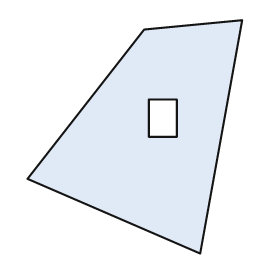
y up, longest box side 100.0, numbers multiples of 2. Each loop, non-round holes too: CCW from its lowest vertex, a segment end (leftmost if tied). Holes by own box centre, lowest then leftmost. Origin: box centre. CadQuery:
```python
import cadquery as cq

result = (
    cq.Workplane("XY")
    .moveTo(28.0, -50.0)
    .lineTo(46.0, 50.0)
    .lineTo(4.0, 46.0)
    .lineTo(-46.0, -18.0)
    .close()
    .moveTo(6.0, 0.0)
    .lineTo(18.0, 0.0)
    .lineTo(18.0, 16.0)
    .lineTo(6.0, 16.0)
    .close()
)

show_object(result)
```